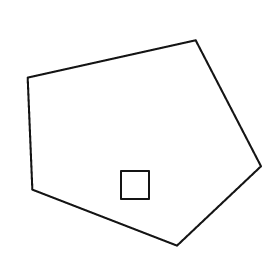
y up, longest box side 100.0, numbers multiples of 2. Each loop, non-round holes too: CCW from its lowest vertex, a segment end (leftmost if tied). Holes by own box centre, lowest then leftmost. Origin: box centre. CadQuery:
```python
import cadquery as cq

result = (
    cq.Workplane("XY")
    .moveTo(14.0, -44.0)
    .lineTo(50.0, -10.0)
    .lineTo(22.0, 44.0)
    .lineTo(-50.0, 28.0)
    .lineTo(-48.0, -20.0)
    .close()
    .moveTo(-10.0, -24.0)
    .lineTo(2.0, -24.0)
    .lineTo(2.0, -12.0)
    .lineTo(-10.0, -12.0)
    .close()
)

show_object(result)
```